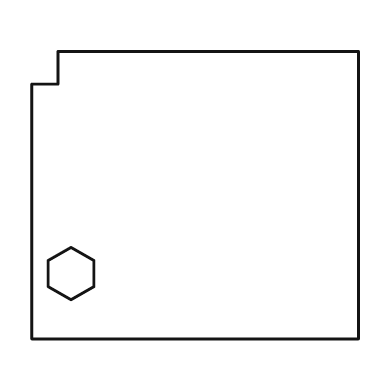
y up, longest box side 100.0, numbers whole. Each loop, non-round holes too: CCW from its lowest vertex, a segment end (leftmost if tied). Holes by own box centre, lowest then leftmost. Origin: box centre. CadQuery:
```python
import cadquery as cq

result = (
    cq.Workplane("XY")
    .moveTo(-50.0, -44.0)
    .lineTo(50.0, -44.0)
    .lineTo(50.0, 44.0)
    .lineTo(-42.0, 44.0)
    .lineTo(-42.0, 34.0)
    .lineTo(-50.0, 34.0)
    .close()
    .moveTo(-38.0, -32.0)
    .lineTo(-31.0, -28.0)
    .lineTo(-31.0, -20.0)
    .lineTo(-38.0, -16.0)
    .lineTo(-45.0, -20.0)
    .lineTo(-45.0, -28.0)
    .close()
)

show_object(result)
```